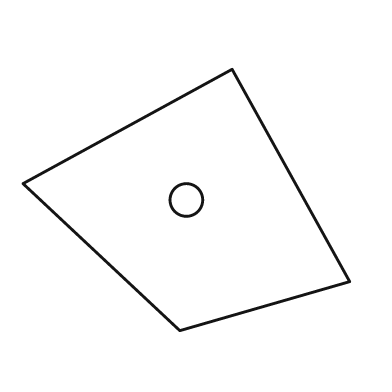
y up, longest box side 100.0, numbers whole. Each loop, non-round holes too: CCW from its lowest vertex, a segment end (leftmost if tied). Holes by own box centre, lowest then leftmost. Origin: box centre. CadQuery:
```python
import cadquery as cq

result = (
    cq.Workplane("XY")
    .moveTo(-2.0, -40.0)
    .lineTo(50.0, -25.0)
    .lineTo(14.0, 40.0)
    .lineTo(-50.0, 5.0)
    .close()
    .moveTo(0.0, 0.0)
    .circle(5.0)
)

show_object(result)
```